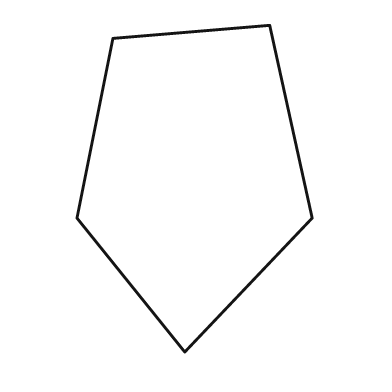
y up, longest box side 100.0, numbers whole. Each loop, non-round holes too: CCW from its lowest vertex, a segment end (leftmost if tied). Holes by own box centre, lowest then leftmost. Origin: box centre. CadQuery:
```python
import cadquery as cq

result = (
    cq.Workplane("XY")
    .moveTo(-3.0, -50.0)
    .lineTo(36.0, -9.0)
    .lineTo(23.0, 50.0)
    .lineTo(-25.0, 46.0)
    .lineTo(-36.0, -9.0)
    .close()
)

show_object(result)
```